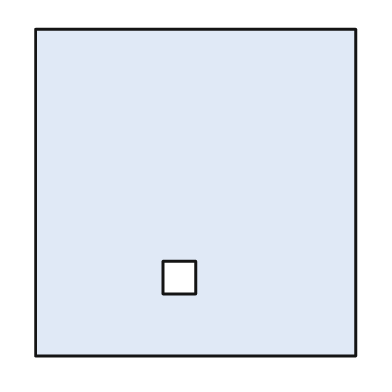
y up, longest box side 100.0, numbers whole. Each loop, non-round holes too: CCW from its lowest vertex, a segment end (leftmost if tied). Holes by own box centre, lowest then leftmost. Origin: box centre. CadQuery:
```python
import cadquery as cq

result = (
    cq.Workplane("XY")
    .moveTo(-49.0, -50.0)
    .lineTo(49.0, -50.0)
    .lineTo(49.0, 50.0)
    .lineTo(-49.0, 50.0)
    .close()
    .moveTo(-10.0, -31.0)
    .lineTo(0.0, -31.0)
    .lineTo(0.0, -21.0)
    .lineTo(-10.0, -21.0)
    .close()
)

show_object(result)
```